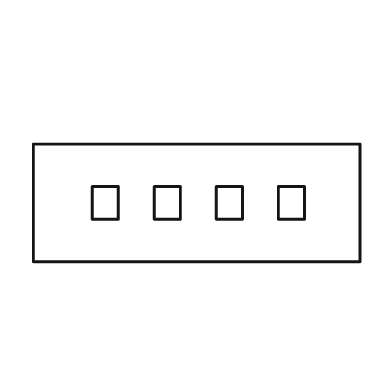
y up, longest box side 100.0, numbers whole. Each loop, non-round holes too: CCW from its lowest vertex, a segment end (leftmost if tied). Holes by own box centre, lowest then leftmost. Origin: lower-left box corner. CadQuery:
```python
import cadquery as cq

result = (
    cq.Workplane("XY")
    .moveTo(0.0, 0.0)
    .lineTo(100.0, 0.0)
    .lineTo(100.0, 36.0)
    .lineTo(0.0, 36.0)
    .close()
    .moveTo(18.0, 13.0)
    .lineTo(26.0, 13.0)
    .lineTo(26.0, 23.0)
    .lineTo(18.0, 23.0)
    .close()
    .moveTo(37.0, 13.0)
    .lineTo(45.0, 13.0)
    .lineTo(45.0, 23.0)
    .lineTo(37.0, 23.0)
    .close()
    .moveTo(56.0, 13.0)
    .lineTo(64.0, 13.0)
    .lineTo(64.0, 23.0)
    .lineTo(56.0, 23.0)
    .close()
    .moveTo(75.0, 13.0)
    .lineTo(83.0, 13.0)
    .lineTo(83.0, 23.0)
    .lineTo(75.0, 23.0)
    .close()
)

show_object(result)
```